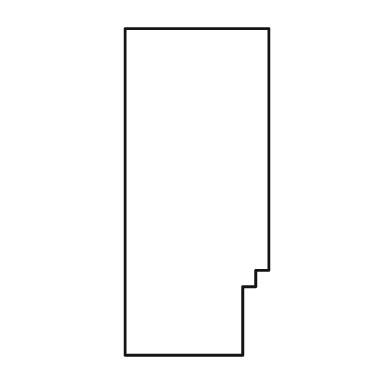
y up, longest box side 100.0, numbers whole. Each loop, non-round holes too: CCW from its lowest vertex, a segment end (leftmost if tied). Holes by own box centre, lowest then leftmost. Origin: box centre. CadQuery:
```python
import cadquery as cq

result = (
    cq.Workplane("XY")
    .moveTo(-22.0, -50.0)
    .lineTo(14.0, -50.0)
    .lineTo(14.0, -29.0)
    .lineTo(18.0, -29.0)
    .lineTo(18.0, -24.0)
    .lineTo(22.0, -24.0)
    .lineTo(22.0, 50.0)
    .lineTo(-22.0, 50.0)
    .close()
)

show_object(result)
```